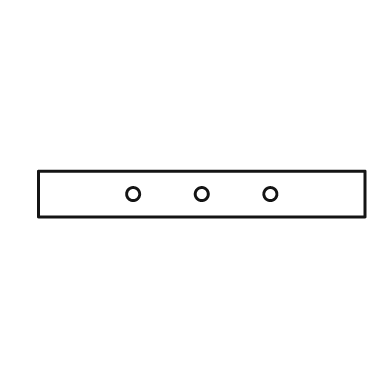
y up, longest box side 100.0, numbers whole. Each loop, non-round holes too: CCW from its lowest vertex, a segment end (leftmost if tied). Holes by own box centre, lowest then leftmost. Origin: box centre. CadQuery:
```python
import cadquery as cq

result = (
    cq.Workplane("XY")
    .moveTo(-50.0, -7.0)
    .lineTo(50.0, -7.0)
    .lineTo(50.0, 7.0)
    .lineTo(-50.0, 7.0)
    .close()
    .moveTo(-21.0, 0.0)
    .circle(2.0)
    .moveTo(0.0, 0.0)
    .circle(2.0)
    .moveTo(21.0, 0.0)
    .circle(2.0)
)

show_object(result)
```